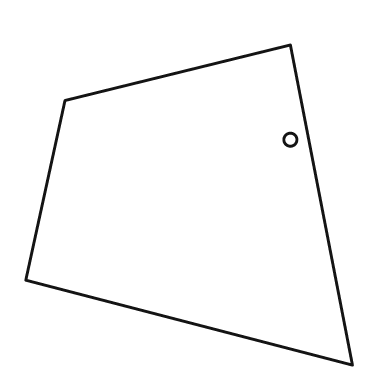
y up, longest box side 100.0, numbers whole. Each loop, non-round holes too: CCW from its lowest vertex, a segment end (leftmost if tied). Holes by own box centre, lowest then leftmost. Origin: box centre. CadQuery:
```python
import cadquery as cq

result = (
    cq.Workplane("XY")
    .moveTo(50.0, -49.0)
    .lineTo(31.0, 49.0)
    .lineTo(-38.0, 32.0)
    .lineTo(-50.0, -23.0)
    .close()
    .moveTo(31.0, 20.0)
    .circle(2.0)
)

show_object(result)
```